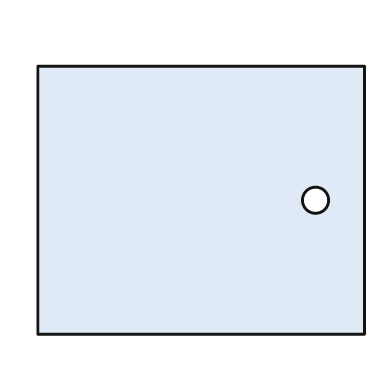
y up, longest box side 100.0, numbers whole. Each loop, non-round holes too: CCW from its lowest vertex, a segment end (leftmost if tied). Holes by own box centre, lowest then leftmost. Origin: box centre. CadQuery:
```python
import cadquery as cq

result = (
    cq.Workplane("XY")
    .moveTo(-50.0, -41.0)
    .lineTo(50.0, -41.0)
    .lineTo(50.0, 41.0)
    .lineTo(-50.0, 41.0)
    .close()
    .moveTo(35.0, 0.0)
    .circle(4.0)
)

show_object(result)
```